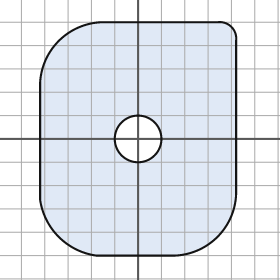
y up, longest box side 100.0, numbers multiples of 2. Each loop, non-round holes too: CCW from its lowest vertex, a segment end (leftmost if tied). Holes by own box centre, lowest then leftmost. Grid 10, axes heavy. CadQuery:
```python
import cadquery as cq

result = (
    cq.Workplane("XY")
    .moveTo(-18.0, -50.0)
    .lineTo(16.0, -50.0)
    .threePointArc((34.0, -42.0), (42.0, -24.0))
    .lineTo(42.0, 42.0)
    .threePointArc((40.0, 48.0), (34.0, 50.0))
    .lineTo(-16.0, 50.0)
    .threePointArc((-34.0, 42.0), (-42.0, 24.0))
    .lineTo(-42.0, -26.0)
    .threePointArc((-34.0, -42.0), (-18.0, -50.0))
    .close()
    .moveTo(0.0, 0.0)
    .circle(10.0)
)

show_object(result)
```